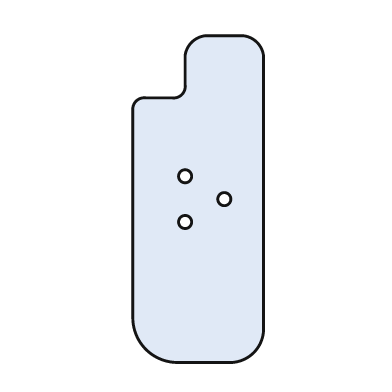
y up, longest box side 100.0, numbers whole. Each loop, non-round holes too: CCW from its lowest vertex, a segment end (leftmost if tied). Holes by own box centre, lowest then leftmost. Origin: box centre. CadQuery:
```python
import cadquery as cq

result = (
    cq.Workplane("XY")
    .moveTo(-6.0, -50.0)
    .lineTo(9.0, -50.0)
    .threePointArc((17.0, -47.0), (20.0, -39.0))
    .lineTo(20.0, 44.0)
    .threePointArc((18.0, 48.0), (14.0, 50.0))
    .lineTo(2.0, 50.0)
    .threePointArc((-2.0, 48.0), (-4.0, 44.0))
    .lineTo(-4.0, 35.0)
    .threePointArc((-5.0, 32.0), (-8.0, 31.0))
    .lineTo(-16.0, 31.0)
    .threePointArc((-19.0, 30.0), (-20.0, 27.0))
    .lineTo(-20.0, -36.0)
    .threePointArc((-16.0, -46.0), (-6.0, -50.0))
    .close()
    .moveTo(-4.0, -7.0)
    .circle(2.0)
    .moveTo(8.0, 0.0)
    .circle(2.0)
    .moveTo(-4.0, 7.0)
    .circle(2.0)
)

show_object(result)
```